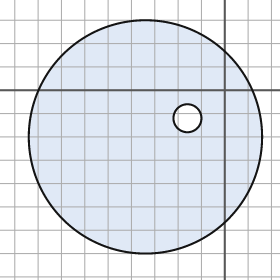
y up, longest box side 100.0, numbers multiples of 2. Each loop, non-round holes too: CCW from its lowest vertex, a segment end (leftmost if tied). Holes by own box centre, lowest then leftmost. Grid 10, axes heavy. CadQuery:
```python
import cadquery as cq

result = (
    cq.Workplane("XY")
    .moveTo(-34.0, -20.0)
    .circle(50.0)
    .moveTo(-16.0, -12.0)
    .circle(6.0)
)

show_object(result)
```